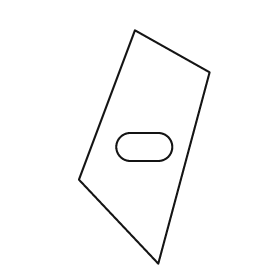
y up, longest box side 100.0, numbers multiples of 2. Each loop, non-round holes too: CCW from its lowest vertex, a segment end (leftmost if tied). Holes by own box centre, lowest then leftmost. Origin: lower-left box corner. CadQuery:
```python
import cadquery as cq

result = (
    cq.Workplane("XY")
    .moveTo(34.0, 0.0)
    .lineTo(56.0, 82.0)
    .lineTo(24.0, 100.0)
    .lineTo(0.0, 36.0)
    .close()
    .moveTo(22.0, 44.0)
    .lineTo(34.0, 44.0)
    .threePointArc((40.0, 50.0), (34.0, 56.0))
    .lineTo(22.0, 56.0)
    .threePointArc((16.0, 50.0), (22.0, 44.0))
    .close()
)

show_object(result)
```